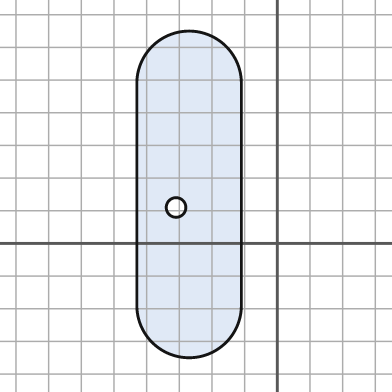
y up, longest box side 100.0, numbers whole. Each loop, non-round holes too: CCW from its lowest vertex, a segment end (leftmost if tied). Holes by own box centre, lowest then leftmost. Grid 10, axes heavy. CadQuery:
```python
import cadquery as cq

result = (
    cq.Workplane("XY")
    .moveTo(-43.0, -19.0)
    .threePointArc((-27.0, -35.0), (-11.0, -19.0))
    .lineTo(-11.0, 49.0)
    .threePointArc((-27.0, 65.0), (-43.0, 49.0))
    .close()
    .moveTo(-31.0, 11.0)
    .circle(3.0)
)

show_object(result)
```